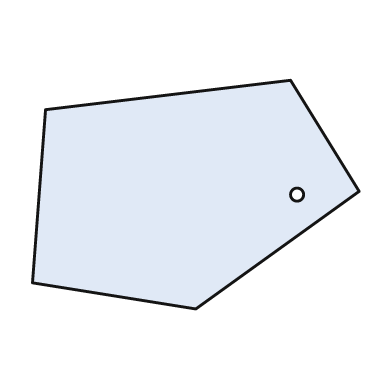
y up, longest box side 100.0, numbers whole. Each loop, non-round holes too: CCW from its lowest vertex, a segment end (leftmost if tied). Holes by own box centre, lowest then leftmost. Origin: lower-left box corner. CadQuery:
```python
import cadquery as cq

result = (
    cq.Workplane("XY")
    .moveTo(50.0, 0.0)
    .lineTo(100.0, 36.0)
    .lineTo(79.0, 70.0)
    .lineTo(4.0, 61.0)
    .lineTo(0.0, 8.0)
    .close()
    .moveTo(81.0, 35.0)
    .circle(2.0)
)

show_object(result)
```